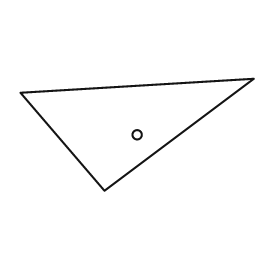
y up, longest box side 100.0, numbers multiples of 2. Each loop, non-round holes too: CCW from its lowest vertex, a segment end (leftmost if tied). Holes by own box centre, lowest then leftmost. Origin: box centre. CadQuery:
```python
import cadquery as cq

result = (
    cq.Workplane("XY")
    .moveTo(-14.0, -24.0)
    .lineTo(50.0, 24.0)
    .lineTo(-50.0, 18.0)
    .close()
    .moveTo(0.0, 0.0)
    .circle(2.0)
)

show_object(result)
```